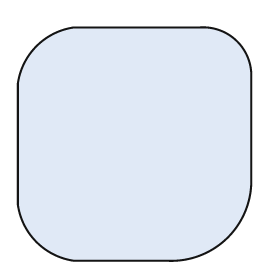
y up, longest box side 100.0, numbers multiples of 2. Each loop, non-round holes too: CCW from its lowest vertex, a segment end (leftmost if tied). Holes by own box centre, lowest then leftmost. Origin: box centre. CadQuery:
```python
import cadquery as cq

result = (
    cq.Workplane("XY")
    .moveTo(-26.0, -50.0)
    .lineTo(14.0, -50.0)
    .threePointArc((40.0, -40.0), (50.0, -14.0))
    .lineTo(50.0, 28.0)
    .threePointArc((44.0, 44.0), (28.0, 50.0))
    .lineTo(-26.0, 50.0)
    .threePointArc((-42.0, 42.0), (-50.0, 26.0))
    .lineTo(-50.0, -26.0)
    .threePointArc((-42.0, -42.0), (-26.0, -50.0))
    .close()
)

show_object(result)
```